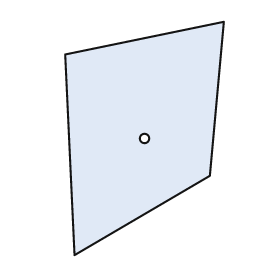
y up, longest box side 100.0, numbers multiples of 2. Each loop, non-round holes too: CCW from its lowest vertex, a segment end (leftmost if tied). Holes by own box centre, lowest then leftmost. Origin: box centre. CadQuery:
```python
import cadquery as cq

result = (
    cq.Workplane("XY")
    .moveTo(-30.0, -50.0)
    .lineTo(28.0, -16.0)
    .lineTo(34.0, 50.0)
    .lineTo(-34.0, 36.0)
    .close()
    .moveTo(0.0, 0.0)
    .circle(2.0)
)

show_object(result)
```